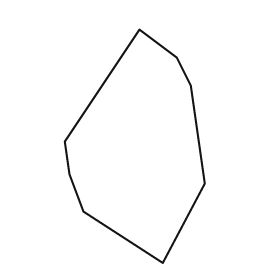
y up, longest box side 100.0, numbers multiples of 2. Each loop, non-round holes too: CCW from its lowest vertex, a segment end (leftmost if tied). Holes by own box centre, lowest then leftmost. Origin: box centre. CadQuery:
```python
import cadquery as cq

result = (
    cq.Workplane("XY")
    .moveTo(12.0, -50.0)
    .lineTo(30.0, -16.0)
    .lineTo(24.0, 26.0)
    .lineTo(18.0, 38.0)
    .lineTo(2.0, 50.0)
    .lineTo(-30.0, 2.0)
    .lineTo(-28.0, -12.0)
    .lineTo(-22.0, -28.0)
    .close()
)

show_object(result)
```